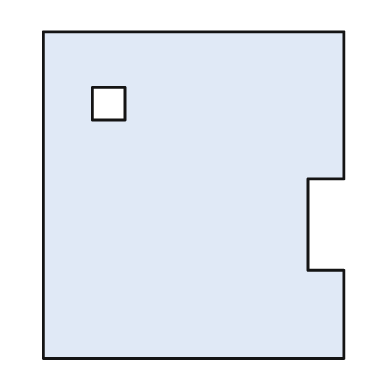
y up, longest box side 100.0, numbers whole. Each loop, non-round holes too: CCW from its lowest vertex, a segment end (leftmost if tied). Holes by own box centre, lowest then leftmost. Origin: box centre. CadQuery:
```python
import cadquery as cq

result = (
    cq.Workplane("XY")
    .moveTo(-46.0, -50.0)
    .lineTo(46.0, -50.0)
    .lineTo(46.0, -23.0)
    .lineTo(35.0, -23.0)
    .lineTo(35.0, 5.0)
    .lineTo(46.0, 5.0)
    .lineTo(46.0, 50.0)
    .lineTo(-46.0, 50.0)
    .close()
    .moveTo(-31.0, 23.0)
    .lineTo(-21.0, 23.0)
    .lineTo(-21.0, 33.0)
    .lineTo(-31.0, 33.0)
    .close()
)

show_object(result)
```